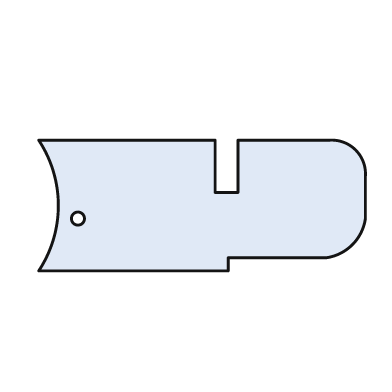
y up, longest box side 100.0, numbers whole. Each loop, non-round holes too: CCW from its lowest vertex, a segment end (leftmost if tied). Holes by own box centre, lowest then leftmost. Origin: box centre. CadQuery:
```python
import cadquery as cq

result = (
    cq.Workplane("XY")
    .moveTo(-50.0, -20.0)
    .lineTo(8.0, -20.0)
    .lineTo(8.0, -16.0)
    .lineTo(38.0, -16.0)
    .threePointArc((46.0, -12.0), (50.0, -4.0))
    .lineTo(50.0, 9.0)
    .threePointArc((47.0, 17.0), (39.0, 20.0))
    .lineTo(11.0, 20.0)
    .lineTo(11.0, 4.0)
    .lineTo(4.0, 4.0)
    .lineTo(4.0, 20.0)
    .lineTo(-50.0, 20.0)
    .threePointArc((-44.0, 0.0), (-50.0, -20.0))
    .close()
    .moveTo(-38.0, -4.0)
    .circle(2.0)
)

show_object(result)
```